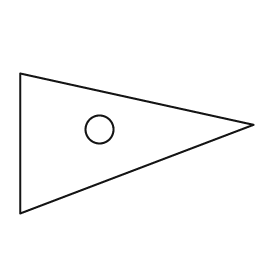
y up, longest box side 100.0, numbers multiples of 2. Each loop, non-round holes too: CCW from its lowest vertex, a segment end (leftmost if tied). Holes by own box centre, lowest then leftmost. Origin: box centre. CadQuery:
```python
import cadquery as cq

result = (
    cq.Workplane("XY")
    .moveTo(-50.0, -30.0)
    .lineTo(50.0, 8.0)
    .lineTo(-50.0, 30.0)
    .close()
    .moveTo(-16.0, 6.0)
    .circle(6.0)
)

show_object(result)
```